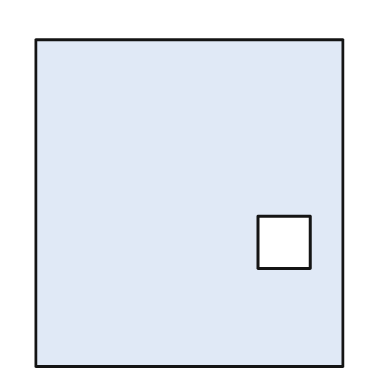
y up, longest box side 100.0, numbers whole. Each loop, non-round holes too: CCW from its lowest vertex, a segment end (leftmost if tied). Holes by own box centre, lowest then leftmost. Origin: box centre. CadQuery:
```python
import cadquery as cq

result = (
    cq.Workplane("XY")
    .moveTo(-47.0, -50.0)
    .lineTo(47.0, -50.0)
    .lineTo(47.0, 50.0)
    .lineTo(-47.0, 50.0)
    .close()
    .moveTo(21.0, -20.0)
    .lineTo(37.0, -20.0)
    .lineTo(37.0, -4.0)
    .lineTo(21.0, -4.0)
    .close()
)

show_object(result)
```